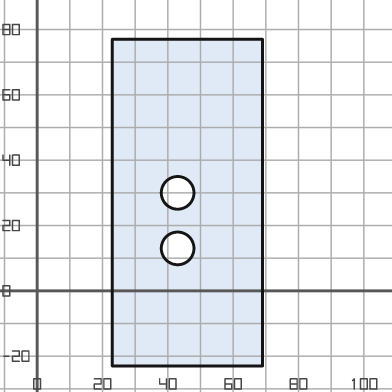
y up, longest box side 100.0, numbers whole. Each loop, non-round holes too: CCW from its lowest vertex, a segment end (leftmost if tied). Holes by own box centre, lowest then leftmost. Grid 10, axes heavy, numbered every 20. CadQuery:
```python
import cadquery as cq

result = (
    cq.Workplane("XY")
    .moveTo(23.0, -23.0)
    .lineTo(69.0, -23.0)
    .lineTo(69.0, 77.0)
    .lineTo(23.0, 77.0)
    .close()
    .moveTo(43.0, 13.0)
    .circle(5.0)
    .moveTo(43.0, 30.0)
    .circle(5.0)
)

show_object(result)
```